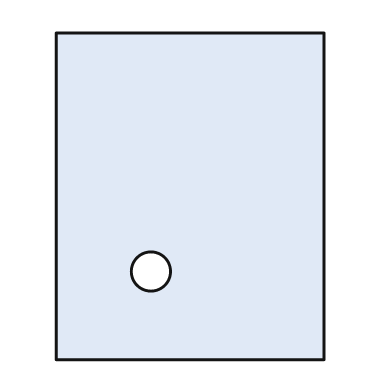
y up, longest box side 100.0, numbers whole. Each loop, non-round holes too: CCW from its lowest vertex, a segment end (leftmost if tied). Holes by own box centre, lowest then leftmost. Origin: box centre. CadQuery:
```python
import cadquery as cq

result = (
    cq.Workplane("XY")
    .moveTo(-41.0, -50.0)
    .lineTo(41.0, -50.0)
    .lineTo(41.0, 50.0)
    .lineTo(-41.0, 50.0)
    .close()
    .moveTo(-12.0, -23.0)
    .circle(6.0)
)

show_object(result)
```